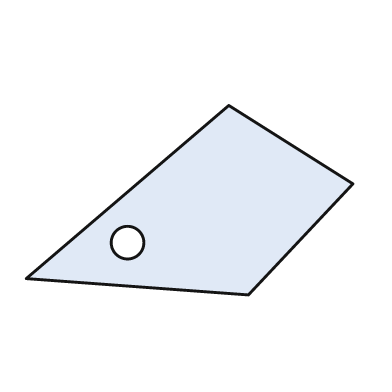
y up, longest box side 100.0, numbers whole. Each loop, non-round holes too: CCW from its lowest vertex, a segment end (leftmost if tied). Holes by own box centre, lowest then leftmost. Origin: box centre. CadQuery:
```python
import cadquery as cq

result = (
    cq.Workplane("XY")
    .moveTo(18.0, -29.0)
    .lineTo(50.0, 5.0)
    .lineTo(12.0, 29.0)
    .lineTo(-50.0, -24.0)
    .close()
    .moveTo(-19.0, -13.0)
    .circle(5.0)
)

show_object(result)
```